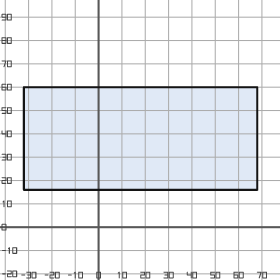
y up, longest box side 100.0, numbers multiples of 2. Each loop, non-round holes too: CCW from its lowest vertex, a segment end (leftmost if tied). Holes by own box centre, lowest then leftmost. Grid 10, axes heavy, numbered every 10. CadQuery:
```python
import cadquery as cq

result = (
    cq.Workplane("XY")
    .moveTo(-32.0, 16.0)
    .lineTo(68.0, 16.0)
    .lineTo(68.0, 60.0)
    .lineTo(-32.0, 60.0)
    .close()
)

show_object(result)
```